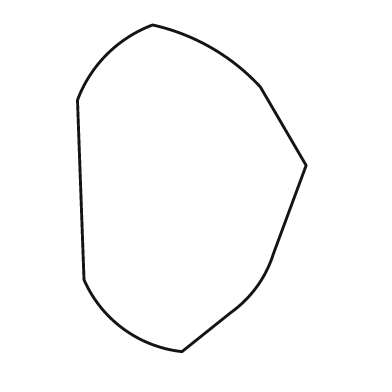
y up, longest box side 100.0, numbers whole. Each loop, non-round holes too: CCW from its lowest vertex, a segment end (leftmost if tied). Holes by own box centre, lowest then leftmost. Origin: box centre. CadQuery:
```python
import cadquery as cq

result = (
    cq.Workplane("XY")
    .moveTo(-3.0, -50.0)
    .lineTo(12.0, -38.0)
    .threePointArc((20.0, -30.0), (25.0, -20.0))
    .lineTo(35.0, 7.0)
    .lineTo(21.0, 31.0)
    .threePointArc((6.0, 43.0), (-12.0, 50.0))
    .threePointArc((-26.0, 41.0), (-35.0, 27.0))
    .lineTo(-33.0, -28.0)
    .threePointArc((-21.0, -43.0), (-3.0, -50.0))
    .close()
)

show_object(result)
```